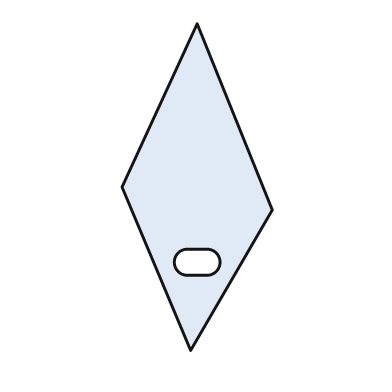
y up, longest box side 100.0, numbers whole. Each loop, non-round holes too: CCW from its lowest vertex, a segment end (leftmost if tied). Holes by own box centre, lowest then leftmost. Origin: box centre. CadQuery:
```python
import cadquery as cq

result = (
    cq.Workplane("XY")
    .moveTo(-2.0, -50.0)
    .lineTo(23.0, -7.0)
    .lineTo(0.0, 50.0)
    .lineTo(-23.0, 0.0)
    .close()
    .moveTo(-3.0, -27.0)
    .lineTo(3.0, -27.0)
    .threePointArc((7.0, -23.0), (3.0, -19.0))
    .lineTo(-3.0, -19.0)
    .threePointArc((-7.0, -23.0), (-3.0, -27.0))
    .close()
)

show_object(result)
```